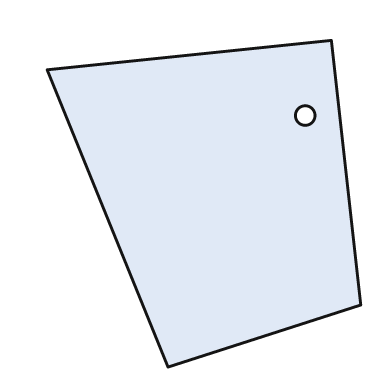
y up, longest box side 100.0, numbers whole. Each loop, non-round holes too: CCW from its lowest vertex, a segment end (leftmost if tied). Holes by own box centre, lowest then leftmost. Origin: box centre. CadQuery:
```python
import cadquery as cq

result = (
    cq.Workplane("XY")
    .moveTo(-11.0, -50.0)
    .lineTo(48.0, -31.0)
    .lineTo(39.0, 50.0)
    .lineTo(-48.0, 41.0)
    .close()
    .moveTo(31.0, 27.0)
    .circle(3.0)
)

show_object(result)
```